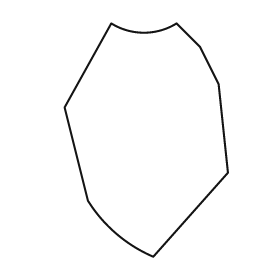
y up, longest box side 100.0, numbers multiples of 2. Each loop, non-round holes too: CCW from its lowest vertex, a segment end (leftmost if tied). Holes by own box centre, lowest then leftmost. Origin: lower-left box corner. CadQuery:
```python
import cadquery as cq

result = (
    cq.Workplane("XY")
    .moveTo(38.0, 0.0)
    .lineTo(70.0, 36.0)
    .lineTo(66.0, 74.0)
    .lineTo(58.0, 90.0)
    .lineTo(48.0, 100.0)
    .threePointArc((34.0, 96.0), (20.0, 100.0))
    .lineTo(0.0, 64.0)
    .lineTo(10.0, 24.0)
    .threePointArc((22.0, 10.0), (38.0, 0.0))
    .close()
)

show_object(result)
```